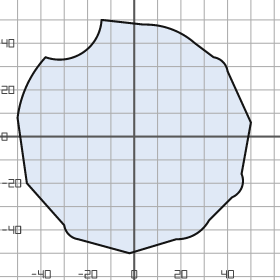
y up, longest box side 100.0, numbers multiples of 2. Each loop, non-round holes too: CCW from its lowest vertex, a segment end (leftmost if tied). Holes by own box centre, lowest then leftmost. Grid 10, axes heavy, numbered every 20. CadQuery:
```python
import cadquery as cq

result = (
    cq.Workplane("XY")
    .moveTo(-2.0, -50.0)
    .lineTo(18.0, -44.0)
    .threePointArc((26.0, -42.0), (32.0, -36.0))
    .lineTo(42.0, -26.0)
    .threePointArc((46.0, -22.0), (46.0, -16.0))
    .lineTo(50.0, 6.0)
    .lineTo(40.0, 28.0)
    .threePointArc((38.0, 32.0), (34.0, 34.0))
    .lineTo(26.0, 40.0)
    .threePointArc((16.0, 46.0), (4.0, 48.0))
    .lineTo(-14.0, 50.0)
    .threePointArc((-22.0, 36.0), (-38.0, 34.0))
    .threePointArc((-46.0, 22.0), (-50.0, 8.0))
    .lineTo(-46.0, -20.0)
    .lineTo(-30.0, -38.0)
    .threePointArc((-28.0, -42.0), (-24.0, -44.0))
    .close()
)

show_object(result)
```